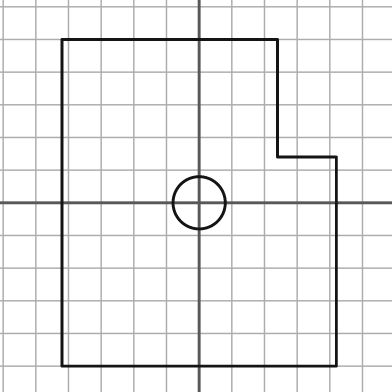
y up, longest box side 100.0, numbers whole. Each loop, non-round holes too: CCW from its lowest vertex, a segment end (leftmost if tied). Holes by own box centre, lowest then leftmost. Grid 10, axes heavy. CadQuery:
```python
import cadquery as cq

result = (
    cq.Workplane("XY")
    .moveTo(-42.0, -50.0)
    .lineTo(42.0, -50.0)
    .lineTo(42.0, 14.0)
    .lineTo(24.0, 14.0)
    .lineTo(24.0, 50.0)
    .lineTo(-42.0, 50.0)
    .close()
    .moveTo(0.0, 0.0)
    .circle(8.0)
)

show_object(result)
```